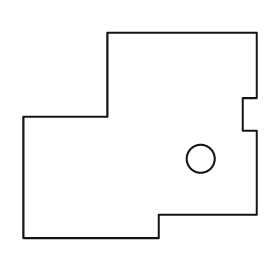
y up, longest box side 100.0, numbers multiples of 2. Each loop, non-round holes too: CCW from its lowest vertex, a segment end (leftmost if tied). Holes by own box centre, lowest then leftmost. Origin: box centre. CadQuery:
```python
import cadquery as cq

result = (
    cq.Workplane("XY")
    .moveTo(-50.0, -44.0)
    .lineTo(8.0, -44.0)
    .lineTo(8.0, -34.0)
    .lineTo(50.0, -34.0)
    .lineTo(50.0, 2.0)
    .lineTo(44.0, 2.0)
    .lineTo(44.0, 16.0)
    .lineTo(50.0, 16.0)
    .lineTo(50.0, 44.0)
    .lineTo(-14.0, 44.0)
    .lineTo(-14.0, 8.0)
    .lineTo(-50.0, 8.0)
    .close()
    .moveTo(26.0, -10.0)
    .circle(6.0)
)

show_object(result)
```